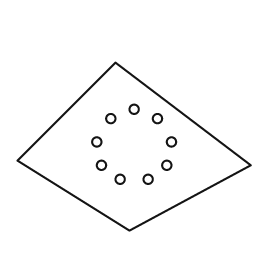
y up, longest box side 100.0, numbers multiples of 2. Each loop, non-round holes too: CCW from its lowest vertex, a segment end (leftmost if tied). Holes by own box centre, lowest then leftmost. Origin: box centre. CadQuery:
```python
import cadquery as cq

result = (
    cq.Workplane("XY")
    .moveTo(-2.0, -36.0)
    .lineTo(50.0, -8.0)
    .lineTo(-8.0, 36.0)
    .lineTo(-50.0, -6.0)
    .close()
    .moveTo(-6.0, -14.0)
    .circle(2.0)
    .moveTo(6.0, -14.0)
    .circle(2.0)
    .moveTo(-14.0, -8.0)
    .circle(2.0)
    .moveTo(14.0, -8.0)
    .circle(2.0)
    .moveTo(-16.0, 2.0)
    .circle(2.0)
    .moveTo(16.0, 2.0)
    .circle(2.0)
    .moveTo(-10.0, 12.0)
    .circle(2.0)
    .moveTo(10.0, 12.0)
    .circle(2.0)
    .moveTo(0.0, 16.0)
    .circle(2.0)
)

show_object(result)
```